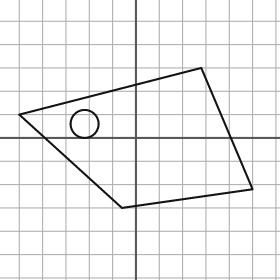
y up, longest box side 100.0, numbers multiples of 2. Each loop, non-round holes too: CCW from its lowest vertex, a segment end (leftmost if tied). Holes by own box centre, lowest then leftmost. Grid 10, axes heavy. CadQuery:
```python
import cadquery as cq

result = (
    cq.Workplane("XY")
    .moveTo(-6.0, -30.0)
    .lineTo(50.0, -22.0)
    .lineTo(28.0, 30.0)
    .lineTo(-50.0, 10.0)
    .close()
    .moveTo(-22.0, 6.0)
    .circle(6.0)
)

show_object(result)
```